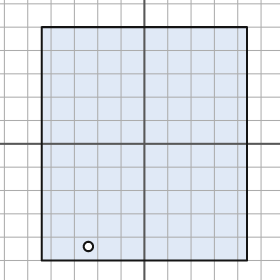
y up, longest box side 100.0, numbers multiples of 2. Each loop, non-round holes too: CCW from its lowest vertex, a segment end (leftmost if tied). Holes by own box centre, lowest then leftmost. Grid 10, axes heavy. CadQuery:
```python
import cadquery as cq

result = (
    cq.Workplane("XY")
    .moveTo(-44.0, -50.0)
    .lineTo(44.0, -50.0)
    .lineTo(44.0, 50.0)
    .lineTo(-44.0, 50.0)
    .close()
    .moveTo(-24.0, -44.0)
    .circle(2.0)
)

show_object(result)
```